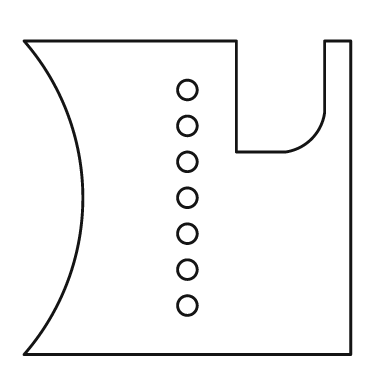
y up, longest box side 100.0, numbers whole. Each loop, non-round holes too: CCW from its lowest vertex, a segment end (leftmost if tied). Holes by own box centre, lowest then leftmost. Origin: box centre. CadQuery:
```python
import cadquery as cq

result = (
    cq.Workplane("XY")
    .moveTo(-50.0, -48.0)
    .lineTo(50.0, -48.0)
    .lineTo(50.0, 48.0)
    .lineTo(42.0, 48.0)
    .lineTo(42.0, 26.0)
    .threePointArc((38.0, 18.0), (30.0, 14.0))
    .lineTo(15.0, 14.0)
    .lineTo(15.0, 48.0)
    .lineTo(-50.0, 48.0)
    .threePointArc((-32.0, 0.0), (-50.0, -48.0))
    .close()
    .moveTo(0.0, -33.0)
    .circle(3.0)
    .moveTo(0.0, -22.0)
    .circle(3.0)
    .moveTo(0.0, -11.0)
    .circle(3.0)
    .moveTo(0.0, 0.0)
    .circle(3.0)
    .moveTo(0.0, 11.0)
    .circle(3.0)
    .moveTo(0.0, 22.0)
    .circle(3.0)
    .moveTo(0.0, 33.0)
    .circle(3.0)
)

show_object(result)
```